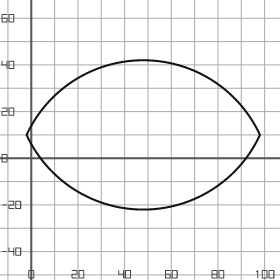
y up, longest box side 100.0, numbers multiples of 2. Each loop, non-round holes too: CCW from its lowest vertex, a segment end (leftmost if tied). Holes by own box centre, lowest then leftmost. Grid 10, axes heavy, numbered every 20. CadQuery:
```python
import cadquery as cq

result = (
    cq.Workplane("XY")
    .moveTo(-2.0, 10.0)
    .threePointArc((48.0, -22.0), (98.0, 10.0))
    .threePointArc((48.0, 42.0), (-2.0, 10.0))
    .close()
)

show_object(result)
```